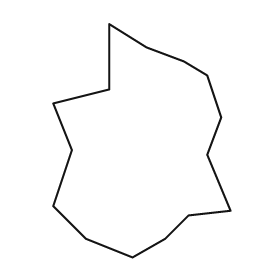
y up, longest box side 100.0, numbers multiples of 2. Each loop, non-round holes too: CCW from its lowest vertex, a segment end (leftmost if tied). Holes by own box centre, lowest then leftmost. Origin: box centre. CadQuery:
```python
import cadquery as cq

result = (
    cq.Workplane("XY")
    .moveTo(-4.0, -50.0)
    .lineTo(10.0, -42.0)
    .lineTo(20.0, -32.0)
    .lineTo(38.0, -30.0)
    .lineTo(28.0, -6.0)
    .lineTo(34.0, 10.0)
    .lineTo(28.0, 28.0)
    .lineTo(18.0, 34.0)
    .lineTo(2.0, 40.0)
    .lineTo(-14.0, 50.0)
    .lineTo(-14.0, 22.0)
    .lineTo(-38.0, 16.0)
    .lineTo(-30.0, -4.0)
    .lineTo(-38.0, -28.0)
    .lineTo(-24.0, -42.0)
    .close()
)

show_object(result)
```